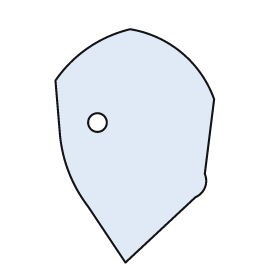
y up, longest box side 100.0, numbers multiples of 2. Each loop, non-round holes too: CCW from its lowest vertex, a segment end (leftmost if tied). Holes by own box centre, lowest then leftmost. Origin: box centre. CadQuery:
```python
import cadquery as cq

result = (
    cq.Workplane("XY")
    .moveTo(-4.0, -50.0)
    .lineTo(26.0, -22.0)
    .threePointArc((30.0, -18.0), (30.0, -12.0))
    .lineTo(34.0, 20.0)
    .threePointArc((20.0, 40.0), (-2.0, 50.0))
    .threePointArc((-20.0, 42.0), (-34.0, 28.0))
    .lineTo(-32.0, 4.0)
    .threePointArc((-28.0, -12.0), (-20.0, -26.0))
    .close()
    .moveTo(-16.0, 10.0)
    .circle(4.0)
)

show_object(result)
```